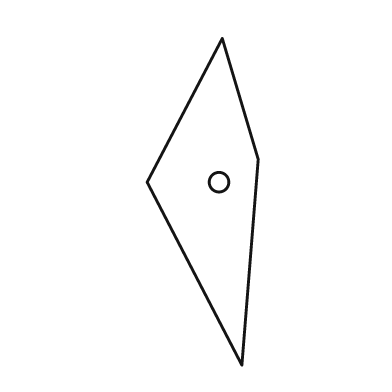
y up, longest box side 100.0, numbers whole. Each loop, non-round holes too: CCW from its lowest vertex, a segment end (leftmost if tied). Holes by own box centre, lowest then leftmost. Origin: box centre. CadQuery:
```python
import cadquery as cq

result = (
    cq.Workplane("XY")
    .moveTo(12.0, -50.0)
    .lineTo(17.0, 13.0)
    .lineTo(6.0, 50.0)
    .lineTo(-17.0, 6.0)
    .close()
    .moveTo(5.0, 6.0)
    .circle(3.0)
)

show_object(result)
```